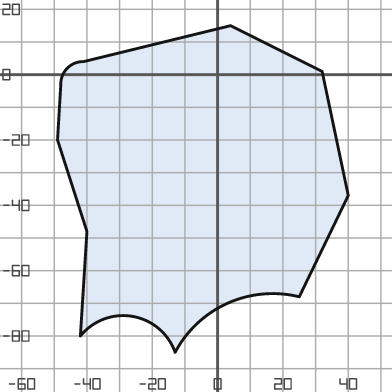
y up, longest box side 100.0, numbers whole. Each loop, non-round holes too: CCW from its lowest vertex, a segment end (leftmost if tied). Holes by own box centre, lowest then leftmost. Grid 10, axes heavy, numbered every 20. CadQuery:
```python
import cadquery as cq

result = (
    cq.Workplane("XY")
    .moveTo(-13.0, -85.0)
    .threePointArc((3.0, -70.0), (25.0, -68.0))
    .lineTo(40.0, -37.0)
    .lineTo(32.0, 1.0)
    .lineTo(4.0, 15.0)
    .lineTo(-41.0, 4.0)
    .threePointArc((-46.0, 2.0), (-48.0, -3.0))
    .lineTo(-49.0, -20.0)
    .lineTo(-40.0, -48.0)
    .lineTo(-42.0, -80.0)
    .threePointArc((-26.0, -74.0), (-13.0, -85.0))
    .close()
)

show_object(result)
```